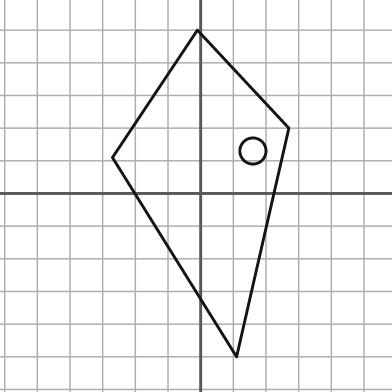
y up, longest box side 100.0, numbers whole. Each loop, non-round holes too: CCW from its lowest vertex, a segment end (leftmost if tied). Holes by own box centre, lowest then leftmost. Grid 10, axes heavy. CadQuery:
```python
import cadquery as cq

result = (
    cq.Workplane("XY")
    .moveTo(11.0, -50.0)
    .lineTo(27.0, 20.0)
    .lineTo(-1.0, 50.0)
    .lineTo(-27.0, 11.0)
    .close()
    .moveTo(16.0, 13.0)
    .circle(4.0)
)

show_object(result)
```